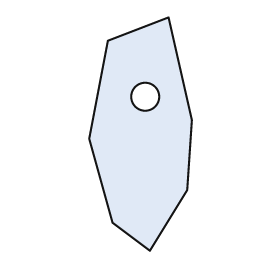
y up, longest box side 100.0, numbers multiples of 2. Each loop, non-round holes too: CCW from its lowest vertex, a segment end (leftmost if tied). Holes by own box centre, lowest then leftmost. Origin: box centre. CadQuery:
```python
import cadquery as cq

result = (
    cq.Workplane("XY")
    .moveTo(4.0, -50.0)
    .lineTo(20.0, -24.0)
    .lineTo(22.0, 6.0)
    .lineTo(12.0, 50.0)
    .lineTo(-14.0, 40.0)
    .lineTo(-22.0, -2.0)
    .lineTo(-12.0, -38.0)
    .close()
    .moveTo(2.0, 16.0)
    .circle(6.0)
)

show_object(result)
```